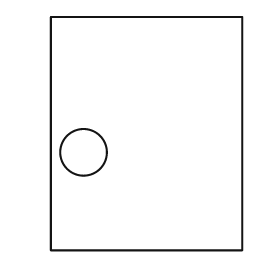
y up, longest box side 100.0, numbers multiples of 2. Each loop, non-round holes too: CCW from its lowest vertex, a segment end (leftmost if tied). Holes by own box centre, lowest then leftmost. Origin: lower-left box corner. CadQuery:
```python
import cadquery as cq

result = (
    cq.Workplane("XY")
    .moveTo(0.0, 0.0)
    .lineTo(82.0, 0.0)
    .lineTo(82.0, 100.0)
    .lineTo(0.0, 100.0)
    .close()
    .moveTo(14.0, 42.0)
    .circle(10.0)
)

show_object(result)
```